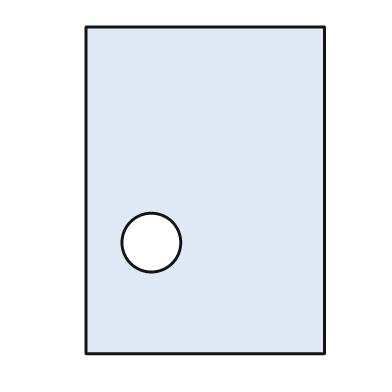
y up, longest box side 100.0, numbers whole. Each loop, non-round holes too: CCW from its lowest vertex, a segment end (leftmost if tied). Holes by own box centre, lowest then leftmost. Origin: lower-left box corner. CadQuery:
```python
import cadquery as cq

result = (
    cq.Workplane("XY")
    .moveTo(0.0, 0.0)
    .lineTo(73.0, 0.0)
    .lineTo(73.0, 100.0)
    .lineTo(0.0, 100.0)
    .close()
    .moveTo(20.0, 34.0)
    .circle(9.0)
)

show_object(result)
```